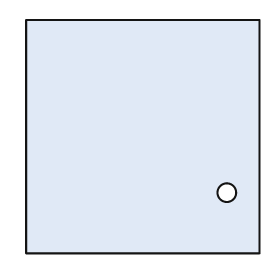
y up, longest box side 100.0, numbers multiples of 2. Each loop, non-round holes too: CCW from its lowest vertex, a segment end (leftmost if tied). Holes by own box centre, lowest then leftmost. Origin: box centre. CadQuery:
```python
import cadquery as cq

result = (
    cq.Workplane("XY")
    .moveTo(-50.0, -50.0)
    .lineTo(50.0, -50.0)
    .lineTo(50.0, 50.0)
    .lineTo(-50.0, 50.0)
    .close()
    .moveTo(36.0, -24.0)
    .circle(4.0)
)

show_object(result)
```